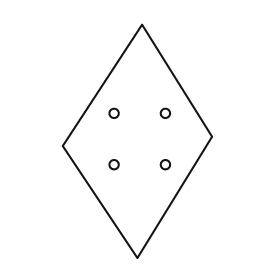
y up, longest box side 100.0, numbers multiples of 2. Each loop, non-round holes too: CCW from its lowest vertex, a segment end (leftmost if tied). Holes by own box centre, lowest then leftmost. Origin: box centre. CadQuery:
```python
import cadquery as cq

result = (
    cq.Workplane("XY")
    .moveTo(0.0, -50.0)
    .lineTo(32.0, 2.0)
    .lineTo(2.0, 50.0)
    .lineTo(-32.0, -2.0)
    .close()
    .moveTo(-10.0, -10.0)
    .circle(2.0)
    .moveTo(12.0, -10.0)
    .circle(2.0)
    .moveTo(-10.0, 12.0)
    .circle(2.0)
    .moveTo(12.0, 12.0)
    .circle(2.0)
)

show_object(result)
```